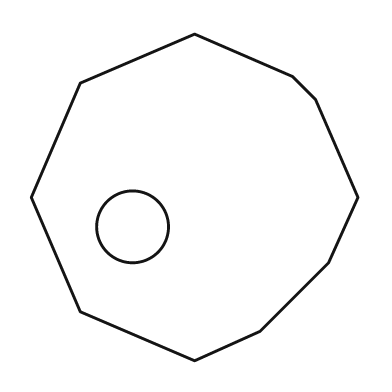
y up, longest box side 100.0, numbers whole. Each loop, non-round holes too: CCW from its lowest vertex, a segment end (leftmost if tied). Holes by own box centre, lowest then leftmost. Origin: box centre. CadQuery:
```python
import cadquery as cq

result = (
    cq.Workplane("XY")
    .moveTo(0.0, -50.0)
    .lineTo(20.0, -41.0)
    .lineTo(41.0, -20.0)
    .lineTo(50.0, 0.0)
    .lineTo(37.0, 30.0)
    .lineTo(30.0, 37.0)
    .lineTo(0.0, 50.0)
    .lineTo(-35.0, 35.0)
    .lineTo(-50.0, 0.0)
    .lineTo(-35.0, -35.0)
    .close()
    .moveTo(-19.0, -9.0)
    .circle(11.0)
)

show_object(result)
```